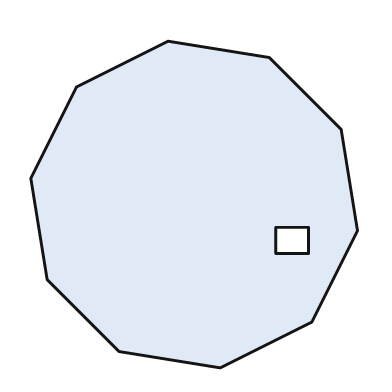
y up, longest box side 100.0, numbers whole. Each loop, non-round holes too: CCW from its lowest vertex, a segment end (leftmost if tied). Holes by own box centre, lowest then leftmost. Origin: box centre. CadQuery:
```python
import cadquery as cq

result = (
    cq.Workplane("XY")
    .moveTo(8.0, -50.0)
    .lineTo(36.0, -36.0)
    .lineTo(50.0, -8.0)
    .lineTo(45.0, 23.0)
    .lineTo(23.0, 45.0)
    .lineTo(-8.0, 50.0)
    .lineTo(-36.0, 36.0)
    .lineTo(-50.0, 8.0)
    .lineTo(-45.0, -23.0)
    .lineTo(-23.0, -45.0)
    .close()
    .moveTo(25.0, -15.0)
    .lineTo(35.0, -15.0)
    .lineTo(35.0, -7.0)
    .lineTo(25.0, -7.0)
    .close()
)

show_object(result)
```